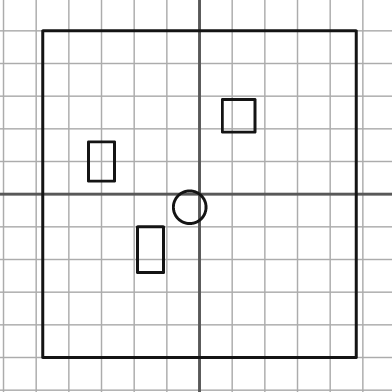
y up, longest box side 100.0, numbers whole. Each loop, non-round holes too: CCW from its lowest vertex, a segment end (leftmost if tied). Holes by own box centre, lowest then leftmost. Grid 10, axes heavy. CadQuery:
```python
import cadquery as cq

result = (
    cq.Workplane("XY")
    .moveTo(-48.0, -50.0)
    .lineTo(48.0, -50.0)
    .lineTo(48.0, 50.0)
    .lineTo(-48.0, 50.0)
    .close()
    .moveTo(-19.0, -24.0)
    .lineTo(-11.0, -24.0)
    .lineTo(-11.0, -10.0)
    .lineTo(-19.0, -10.0)
    .close()
    .moveTo(-3.0, -4.0)
    .circle(5.0)
    .moveTo(-34.0, 4.0)
    .lineTo(-26.0, 4.0)
    .lineTo(-26.0, 16.0)
    .lineTo(-34.0, 16.0)
    .close()
    .moveTo(7.0, 19.0)
    .lineTo(17.0, 19.0)
    .lineTo(17.0, 29.0)
    .lineTo(7.0, 29.0)
    .close()
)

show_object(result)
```